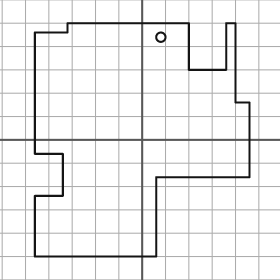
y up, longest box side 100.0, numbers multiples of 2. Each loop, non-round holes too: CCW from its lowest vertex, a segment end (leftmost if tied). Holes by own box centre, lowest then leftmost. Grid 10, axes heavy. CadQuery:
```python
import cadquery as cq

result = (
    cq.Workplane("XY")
    .moveTo(-46.0, -50.0)
    .lineTo(6.0, -50.0)
    .lineTo(6.0, -16.0)
    .lineTo(46.0, -16.0)
    .lineTo(46.0, 16.0)
    .lineTo(40.0, 16.0)
    .lineTo(40.0, 50.0)
    .lineTo(36.0, 50.0)
    .lineTo(36.0, 30.0)
    .lineTo(20.0, 30.0)
    .lineTo(20.0, 50.0)
    .lineTo(-32.0, 50.0)
    .lineTo(-32.0, 46.0)
    .lineTo(-46.0, 46.0)
    .lineTo(-46.0, -6.0)
    .lineTo(-34.0, -6.0)
    .lineTo(-34.0, -24.0)
    .lineTo(-46.0, -24.0)
    .close()
    .moveTo(8.0, 44.0)
    .circle(2.0)
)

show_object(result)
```